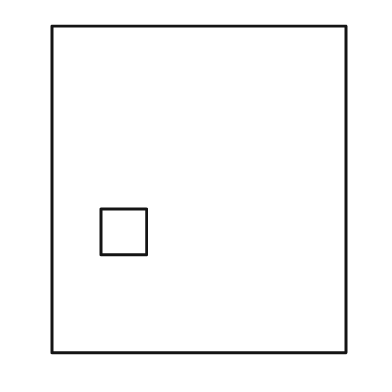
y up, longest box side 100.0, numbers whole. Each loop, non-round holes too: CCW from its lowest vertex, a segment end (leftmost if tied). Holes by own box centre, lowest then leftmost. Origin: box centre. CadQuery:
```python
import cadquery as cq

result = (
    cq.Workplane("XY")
    .moveTo(-45.0, -50.0)
    .lineTo(45.0, -50.0)
    .lineTo(45.0, 50.0)
    .lineTo(-45.0, 50.0)
    .close()
    .moveTo(-30.0, -20.0)
    .lineTo(-16.0, -20.0)
    .lineTo(-16.0, -6.0)
    .lineTo(-30.0, -6.0)
    .close()
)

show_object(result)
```